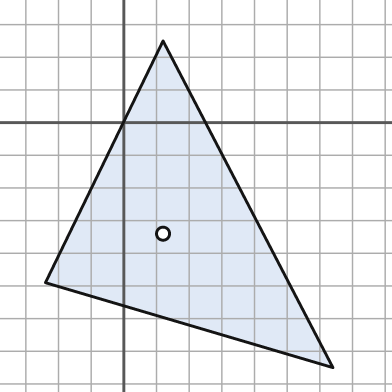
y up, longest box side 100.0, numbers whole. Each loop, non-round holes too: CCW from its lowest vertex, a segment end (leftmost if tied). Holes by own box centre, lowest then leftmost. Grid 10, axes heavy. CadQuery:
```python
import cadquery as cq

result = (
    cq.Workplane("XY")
    .moveTo(64.0, -75.0)
    .lineTo(12.0, 25.0)
    .lineTo(-24.0, -49.0)
    .close()
    .moveTo(12.0, -34.0)
    .circle(2.0)
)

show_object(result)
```